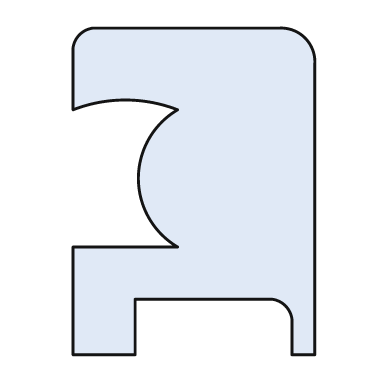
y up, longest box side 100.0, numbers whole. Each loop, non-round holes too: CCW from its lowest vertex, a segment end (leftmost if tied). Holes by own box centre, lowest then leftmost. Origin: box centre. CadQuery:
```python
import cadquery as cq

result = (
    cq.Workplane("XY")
    .moveTo(-37.0, -50.0)
    .lineTo(-18.0, -50.0)
    .lineTo(-18.0, -33.0)
    .lineTo(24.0, -33.0)
    .threePointArc((28.0, -35.0), (30.0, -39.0))
    .lineTo(30.0, -50.0)
    .lineTo(37.0, -50.0)
    .lineTo(37.0, 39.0)
    .threePointArc((34.0, 47.0), (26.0, 50.0))
    .lineTo(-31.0, 50.0)
    .threePointArc((-35.0, 48.0), (-37.0, 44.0))
    .lineTo(-37.0, 25.0)
    .threePointArc((-21.0, 28.0), (-5.0, 25.0))
    .threePointArc((-17.0, 4.0), (-5.0, -17.0))
    .lineTo(-37.0, -17.0)
    .close()
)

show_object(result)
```